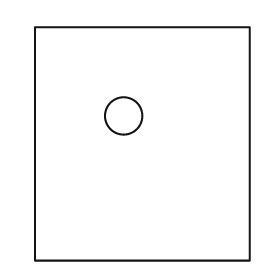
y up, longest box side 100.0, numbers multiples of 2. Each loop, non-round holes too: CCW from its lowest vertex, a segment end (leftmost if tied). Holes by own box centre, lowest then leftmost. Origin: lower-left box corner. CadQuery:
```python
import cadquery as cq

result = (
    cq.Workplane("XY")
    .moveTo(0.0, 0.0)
    .lineTo(92.0, 0.0)
    .lineTo(92.0, 100.0)
    .lineTo(0.0, 100.0)
    .close()
    .moveTo(38.0, 62.0)
    .circle(8.0)
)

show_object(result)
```